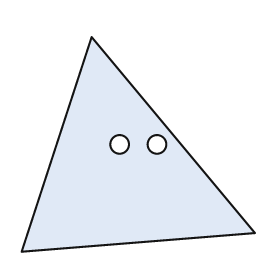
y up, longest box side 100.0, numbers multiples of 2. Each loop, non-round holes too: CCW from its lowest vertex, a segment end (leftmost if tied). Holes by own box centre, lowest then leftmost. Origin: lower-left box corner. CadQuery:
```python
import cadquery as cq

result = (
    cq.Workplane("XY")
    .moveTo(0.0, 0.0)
    .lineTo(100.0, 8.0)
    .lineTo(30.0, 92.0)
    .close()
    .moveTo(42.0, 46.0)
    .circle(4.0)
    .moveTo(58.0, 46.0)
    .circle(4.0)
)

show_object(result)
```